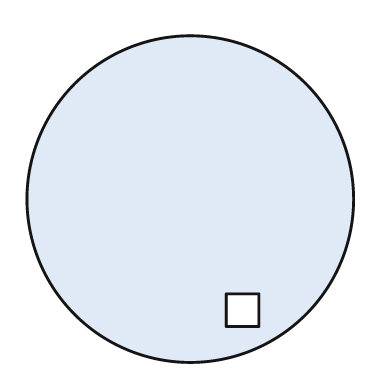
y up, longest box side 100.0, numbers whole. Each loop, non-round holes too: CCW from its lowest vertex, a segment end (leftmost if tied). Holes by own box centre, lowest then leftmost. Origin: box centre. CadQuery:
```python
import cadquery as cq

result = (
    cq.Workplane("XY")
    .moveTo(0.0, 0.0)
    .circle(50.0)
    .moveTo(11.0, -39.0)
    .lineTo(21.0, -39.0)
    .lineTo(21.0, -29.0)
    .lineTo(11.0, -29.0)
    .close()
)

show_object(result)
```